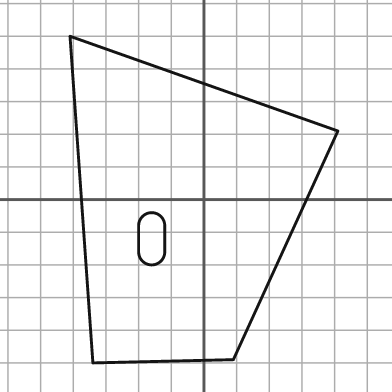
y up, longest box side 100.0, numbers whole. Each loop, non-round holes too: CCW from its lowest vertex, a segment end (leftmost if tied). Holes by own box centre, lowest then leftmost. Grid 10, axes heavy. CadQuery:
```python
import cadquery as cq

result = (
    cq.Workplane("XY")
    .moveTo(-34.0, -50.0)
    .lineTo(9.0, -49.0)
    .lineTo(41.0, 21.0)
    .lineTo(-41.0, 50.0)
    .close()
    .moveTo(-20.0, -16.0)
    .threePointArc((-16.0, -20.0), (-12.0, -16.0))
    .lineTo(-12.0, -8.0)
    .threePointArc((-16.0, -4.0), (-20.0, -8.0))
    .close()
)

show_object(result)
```